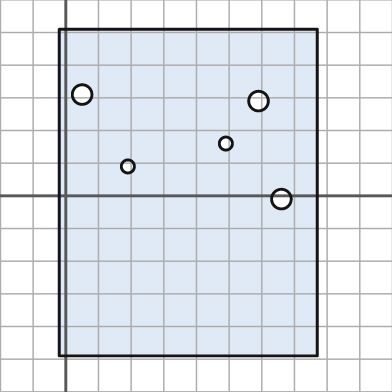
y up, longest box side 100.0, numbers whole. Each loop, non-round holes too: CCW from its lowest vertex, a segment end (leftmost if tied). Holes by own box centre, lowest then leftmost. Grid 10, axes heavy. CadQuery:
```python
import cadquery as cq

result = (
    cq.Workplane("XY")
    .moveTo(-2.0, -49.0)
    .lineTo(77.0, -49.0)
    .lineTo(77.0, 51.0)
    .lineTo(-2.0, 51.0)
    .close()
    .moveTo(66.0, -1.0)
    .circle(3.0)
    .moveTo(19.0, 9.0)
    .circle(2.0)
    .moveTo(49.0, 16.0)
    .circle(2.0)
    .moveTo(59.0, 29.0)
    .circle(3.0)
    .moveTo(5.0, 31.0)
    .circle(3.0)
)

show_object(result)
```